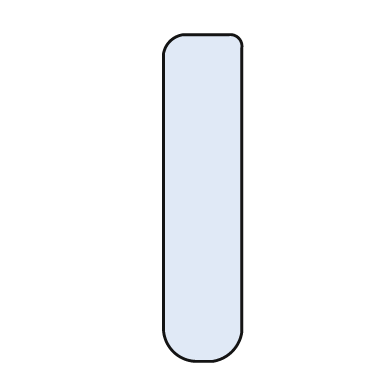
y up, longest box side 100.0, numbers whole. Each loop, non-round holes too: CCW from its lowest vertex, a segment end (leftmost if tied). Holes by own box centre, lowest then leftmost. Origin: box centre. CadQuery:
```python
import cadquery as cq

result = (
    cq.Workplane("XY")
    .moveTo(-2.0, -50.0)
    .lineTo(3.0, -50.0)
    .threePointArc((9.0, -47.0), (12.0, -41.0))
    .lineTo(12.0, 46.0)
    .threePointArc((11.0, 49.0), (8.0, 50.0))
    .lineTo(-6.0, 50.0)
    .threePointArc((-10.0, 48.0), (-12.0, 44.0))
    .lineTo(-12.0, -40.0)
    .threePointArc((-9.0, -47.0), (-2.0, -50.0))
    .close()
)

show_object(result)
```